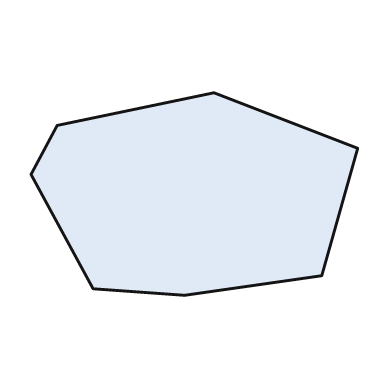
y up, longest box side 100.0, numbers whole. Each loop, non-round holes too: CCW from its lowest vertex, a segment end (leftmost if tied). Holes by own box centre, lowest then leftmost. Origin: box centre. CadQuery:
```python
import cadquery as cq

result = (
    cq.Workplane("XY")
    .moveTo(-3.0, -31.0)
    .lineTo(39.0, -25.0)
    .lineTo(50.0, 14.0)
    .lineTo(6.0, 31.0)
    .lineTo(-42.0, 21.0)
    .lineTo(-50.0, 6.0)
    .lineTo(-31.0, -29.0)
    .close()
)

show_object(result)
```